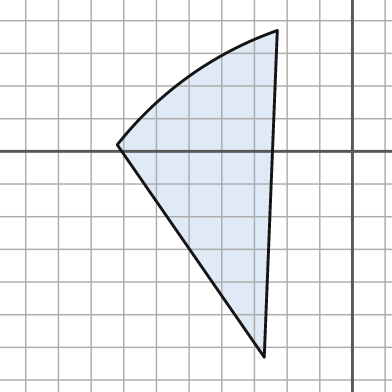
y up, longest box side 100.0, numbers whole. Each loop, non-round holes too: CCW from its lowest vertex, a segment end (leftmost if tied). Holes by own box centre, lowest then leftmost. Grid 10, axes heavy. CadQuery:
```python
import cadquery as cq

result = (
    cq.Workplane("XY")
    .moveTo(-27.0, -63.0)
    .lineTo(-23.0, 37.0)
    .threePointArc((-50.0, 23.0), (-72.0, 2.0))
    .close()
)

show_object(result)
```